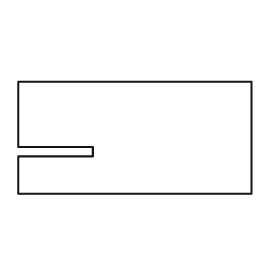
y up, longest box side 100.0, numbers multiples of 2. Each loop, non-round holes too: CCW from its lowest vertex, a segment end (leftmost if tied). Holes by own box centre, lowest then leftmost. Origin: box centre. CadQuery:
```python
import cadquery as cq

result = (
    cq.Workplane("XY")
    .moveTo(-50.0, -24.0)
    .lineTo(50.0, -24.0)
    .lineTo(50.0, 24.0)
    .lineTo(-50.0, 24.0)
    .lineTo(-50.0, -4.0)
    .lineTo(-18.0, -4.0)
    .lineTo(-18.0, -8.0)
    .lineTo(-50.0, -8.0)
    .close()
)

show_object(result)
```